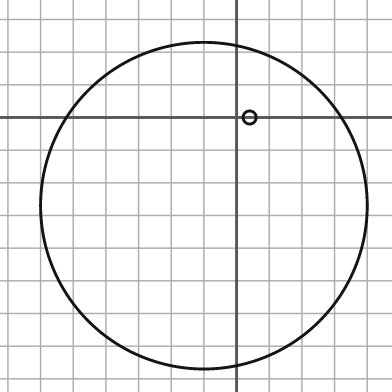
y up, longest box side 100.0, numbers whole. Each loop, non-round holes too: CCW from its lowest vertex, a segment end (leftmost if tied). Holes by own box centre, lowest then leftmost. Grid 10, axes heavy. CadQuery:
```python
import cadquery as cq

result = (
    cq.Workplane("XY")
    .moveTo(-10.0, -27.0)
    .circle(50.0)
    .moveTo(4.0, 0.0)
    .circle(2.0)
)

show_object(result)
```